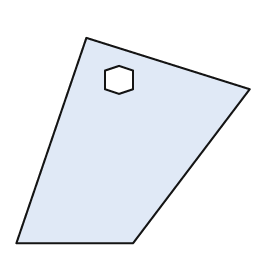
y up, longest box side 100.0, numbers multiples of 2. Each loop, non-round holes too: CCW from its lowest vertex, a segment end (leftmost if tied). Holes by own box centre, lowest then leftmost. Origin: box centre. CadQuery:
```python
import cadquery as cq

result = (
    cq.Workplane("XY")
    .moveTo(-50.0, -44.0)
    .lineTo(0.0, -44.0)
    .lineTo(50.0, 22.0)
    .lineTo(-20.0, 44.0)
    .close()
    .moveTo(-6.0, 20.0)
    .lineTo(0.0, 22.0)
    .lineTo(0.0, 30.0)
    .lineTo(-6.0, 32.0)
    .lineTo(-12.0, 30.0)
    .lineTo(-12.0, 22.0)
    .close()
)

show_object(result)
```